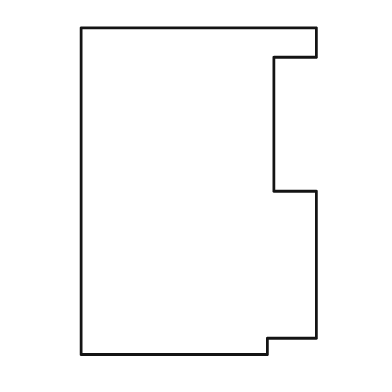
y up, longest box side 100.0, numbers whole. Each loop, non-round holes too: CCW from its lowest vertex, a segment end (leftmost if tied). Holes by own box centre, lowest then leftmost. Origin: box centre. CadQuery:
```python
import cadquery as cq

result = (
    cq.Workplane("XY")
    .moveTo(-36.0, -50.0)
    .lineTo(21.0, -50.0)
    .lineTo(21.0, -45.0)
    .lineTo(36.0, -45.0)
    .lineTo(36.0, 0.0)
    .lineTo(23.0, 0.0)
    .lineTo(23.0, 41.0)
    .lineTo(36.0, 41.0)
    .lineTo(36.0, 50.0)
    .lineTo(-36.0, 50.0)
    .close()
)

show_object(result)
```